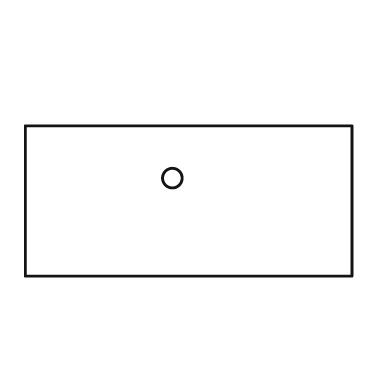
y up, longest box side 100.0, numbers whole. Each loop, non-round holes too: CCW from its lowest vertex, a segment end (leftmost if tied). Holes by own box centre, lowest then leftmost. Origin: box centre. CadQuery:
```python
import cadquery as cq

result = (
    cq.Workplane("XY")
    .moveTo(-50.0, -23.0)
    .lineTo(50.0, -23.0)
    .lineTo(50.0, 23.0)
    .lineTo(-50.0, 23.0)
    .close()
    .moveTo(-5.0, 7.0)
    .circle(3.0)
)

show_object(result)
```